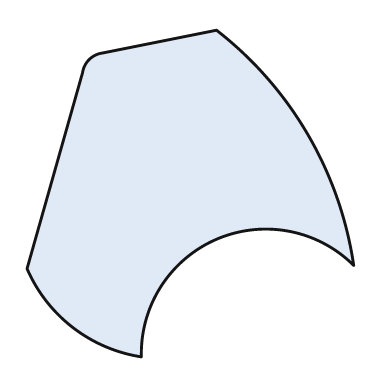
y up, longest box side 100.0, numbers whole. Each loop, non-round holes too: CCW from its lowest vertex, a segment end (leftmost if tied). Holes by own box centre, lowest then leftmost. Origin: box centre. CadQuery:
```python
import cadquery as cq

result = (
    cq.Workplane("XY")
    .moveTo(-15.0, -50.0)
    .threePointArc((8.0, -14.0), (50.0, -22.0))
    .threePointArc((36.0, 18.0), (8.0, 50.0))
    .lineTo(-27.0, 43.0)
    .threePointArc((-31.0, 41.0), (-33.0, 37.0))
    .lineTo(-50.0, -23.0)
    .threePointArc((-36.0, -41.0), (-15.0, -50.0))
    .close()
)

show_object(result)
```